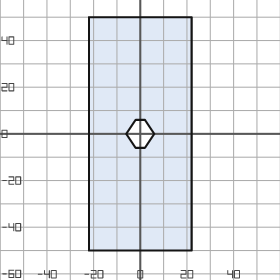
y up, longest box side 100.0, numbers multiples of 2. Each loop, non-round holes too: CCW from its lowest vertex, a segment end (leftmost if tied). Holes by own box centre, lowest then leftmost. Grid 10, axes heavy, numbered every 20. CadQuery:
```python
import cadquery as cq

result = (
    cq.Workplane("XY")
    .moveTo(-22.0, -50.0)
    .lineTo(22.0, -50.0)
    .lineTo(22.0, 50.0)
    .lineTo(-22.0, 50.0)
    .close()
    .moveTo(-2.0, -6.0)
    .lineTo(2.0, -6.0)
    .lineTo(6.0, 0.0)
    .lineTo(2.0, 6.0)
    .lineTo(-2.0, 6.0)
    .lineTo(-6.0, 0.0)
    .close()
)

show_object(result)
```